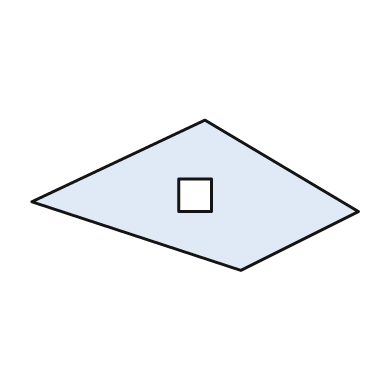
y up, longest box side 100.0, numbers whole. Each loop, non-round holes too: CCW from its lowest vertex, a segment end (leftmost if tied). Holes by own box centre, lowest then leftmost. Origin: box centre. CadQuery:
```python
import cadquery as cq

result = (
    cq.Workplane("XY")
    .moveTo(14.0, -23.0)
    .lineTo(50.0, -5.0)
    .lineTo(3.0, 23.0)
    .lineTo(-50.0, -2.0)
    .close()
    .moveTo(-5.0, -5.0)
    .lineTo(5.0, -5.0)
    .lineTo(5.0, 5.0)
    .lineTo(-5.0, 5.0)
    .close()
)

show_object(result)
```